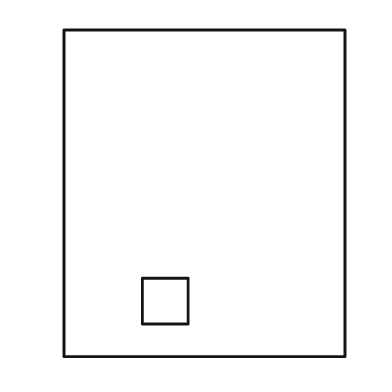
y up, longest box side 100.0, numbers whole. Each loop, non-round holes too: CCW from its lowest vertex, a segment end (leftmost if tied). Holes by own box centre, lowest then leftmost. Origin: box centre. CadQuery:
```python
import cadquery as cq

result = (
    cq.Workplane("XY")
    .moveTo(-43.0, -50.0)
    .lineTo(43.0, -50.0)
    .lineTo(43.0, 50.0)
    .lineTo(-43.0, 50.0)
    .close()
    .moveTo(-19.0, -40.0)
    .lineTo(-5.0, -40.0)
    .lineTo(-5.0, -26.0)
    .lineTo(-19.0, -26.0)
    .close()
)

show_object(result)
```